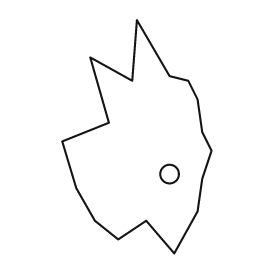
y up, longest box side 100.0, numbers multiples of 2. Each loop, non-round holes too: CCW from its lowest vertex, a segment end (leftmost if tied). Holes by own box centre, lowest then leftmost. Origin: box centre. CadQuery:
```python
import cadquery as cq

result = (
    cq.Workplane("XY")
    .moveTo(16.0, -50.0)
    .lineTo(26.0, -32.0)
    .lineTo(28.0, -18.0)
    .lineTo(32.0, -6.0)
    .lineTo(28.0, 2.0)
    .lineTo(26.0, 16.0)
    .lineTo(22.0, 24.0)
    .lineTo(14.0, 26.0)
    .lineTo(0.0, 50.0)
    .lineTo(-2.0, 24.0)
    .lineTo(-20.0, 34.0)
    .lineTo(-12.0, 6.0)
    .lineTo(-32.0, -2.0)
    .lineTo(-26.0, -22.0)
    .lineTo(-18.0, -36.0)
    .lineTo(-8.0, -44.0)
    .lineTo(4.0, -36.0)
    .close()
    .moveTo(14.0, -16.0)
    .circle(4.0)
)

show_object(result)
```